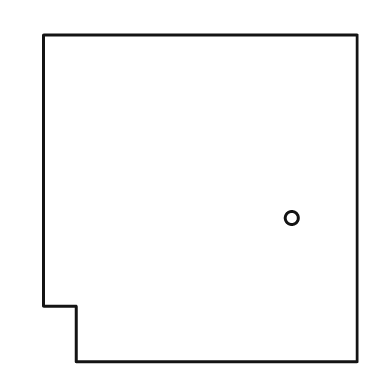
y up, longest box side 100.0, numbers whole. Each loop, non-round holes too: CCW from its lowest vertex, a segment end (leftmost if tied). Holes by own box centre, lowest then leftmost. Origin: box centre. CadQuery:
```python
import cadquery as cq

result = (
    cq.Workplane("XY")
    .moveTo(-38.0, -50.0)
    .lineTo(48.0, -50.0)
    .lineTo(48.0, 50.0)
    .lineTo(-48.0, 50.0)
    .lineTo(-48.0, -33.0)
    .lineTo(-38.0, -33.0)
    .close()
    .moveTo(28.0, -6.0)
    .circle(2.0)
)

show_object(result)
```